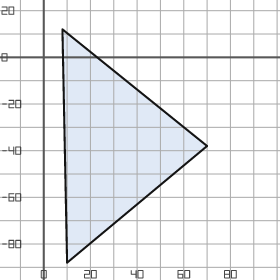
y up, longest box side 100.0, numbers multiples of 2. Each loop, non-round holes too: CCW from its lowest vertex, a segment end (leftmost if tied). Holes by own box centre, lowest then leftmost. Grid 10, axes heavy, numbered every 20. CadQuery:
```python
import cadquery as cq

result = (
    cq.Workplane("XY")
    .moveTo(10.0, -88.0)
    .lineTo(70.0, -38.0)
    .lineTo(8.0, 12.0)
    .close()
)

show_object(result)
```